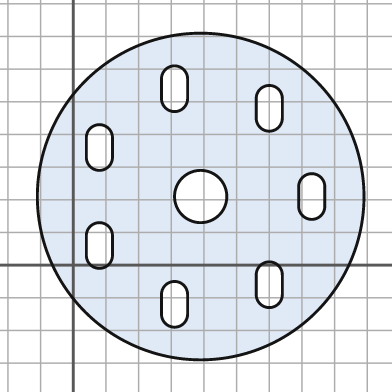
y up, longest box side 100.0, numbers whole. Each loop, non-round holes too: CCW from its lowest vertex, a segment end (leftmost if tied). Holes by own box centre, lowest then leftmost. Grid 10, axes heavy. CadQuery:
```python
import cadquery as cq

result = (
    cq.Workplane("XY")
    .moveTo(39.0, 21.0)
    .circle(50.0)
    .moveTo(27.0, -15.0)
    .threePointArc((31.0, -19.0), (35.0, -15.0))
    .lineTo(35.0, -9.0)
    .threePointArc((31.0, -5.0), (27.0, -9.0))
    .close()
    .moveTo(56.0, -9.0)
    .threePointArc((60.0, -13.0), (64.0, -9.0))
    .lineTo(64.0, -3.0)
    .threePointArc((60.0, 1.0), (56.0, -3.0))
    .close()
    .moveTo(4.0, 3.0)
    .threePointArc((8.0, -1.0), (12.0, 3.0))
    .lineTo(12.0, 9.0)
    .threePointArc((8.0, 13.0), (4.0, 9.0))
    .close()
    .moveTo(39.0, 21.0)
    .circle(8.0)
    .moveTo(69.0, 18.0)
    .threePointArc((73.0, 14.0), (77.0, 18.0))
    .lineTo(77.0, 24.0)
    .threePointArc((73.0, 28.0), (69.0, 24.0))
    .close()
    .moveTo(4.0, 33.0)
    .threePointArc((8.0, 29.0), (12.0, 33.0))
    .lineTo(12.0, 39.0)
    .threePointArc((8.0, 43.0), (4.0, 39.0))
    .close()
    .moveTo(56.0, 45.0)
    .threePointArc((60.0, 41.0), (64.0, 45.0))
    .lineTo(64.0, 51.0)
    .threePointArc((60.0, 55.0), (56.0, 51.0))
    .close()
    .moveTo(27.0, 51.0)
    .threePointArc((31.0, 47.0), (35.0, 51.0))
    .lineTo(35.0, 57.0)
    .threePointArc((31.0, 61.0), (27.0, 57.0))
    .close()
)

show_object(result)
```